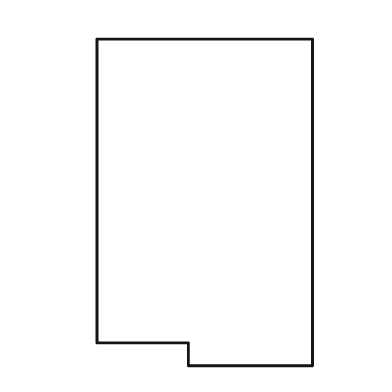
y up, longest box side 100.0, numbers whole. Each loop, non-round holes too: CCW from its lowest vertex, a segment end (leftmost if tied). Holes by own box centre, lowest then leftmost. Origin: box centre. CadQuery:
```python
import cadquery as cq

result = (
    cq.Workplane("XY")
    .moveTo(-5.0, -50.0)
    .lineTo(33.0, -50.0)
    .lineTo(33.0, 50.0)
    .lineTo(-33.0, 50.0)
    .lineTo(-33.0, -43.0)
    .lineTo(-5.0, -43.0)
    .close()
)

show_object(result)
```